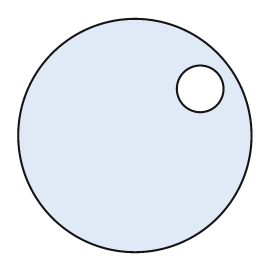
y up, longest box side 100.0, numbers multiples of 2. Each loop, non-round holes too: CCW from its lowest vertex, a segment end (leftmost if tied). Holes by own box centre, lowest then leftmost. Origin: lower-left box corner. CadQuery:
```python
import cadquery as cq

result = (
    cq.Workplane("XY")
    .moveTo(50.0, 50.0)
    .circle(50.0)
    .moveTo(78.0, 70.0)
    .circle(10.0)
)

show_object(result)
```